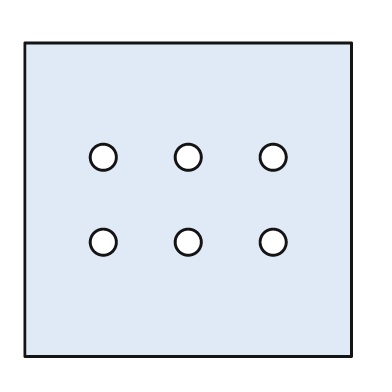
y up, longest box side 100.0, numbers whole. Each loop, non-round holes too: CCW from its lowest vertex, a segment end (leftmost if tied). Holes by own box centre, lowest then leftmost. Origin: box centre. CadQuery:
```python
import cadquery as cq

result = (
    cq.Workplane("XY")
    .moveTo(-50.0, -48.0)
    .lineTo(50.0, -48.0)
    .lineTo(50.0, 48.0)
    .lineTo(-50.0, 48.0)
    .close()
    .moveTo(-26.0, -13.0)
    .circle(4.0)
    .moveTo(0.0, -13.0)
    .circle(4.0)
    .moveTo(26.0, -13.0)
    .circle(4.0)
    .moveTo(-26.0, 13.0)
    .circle(4.0)
    .moveTo(0.0, 13.0)
    .circle(4.0)
    .moveTo(26.0, 13.0)
    .circle(4.0)
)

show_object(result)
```